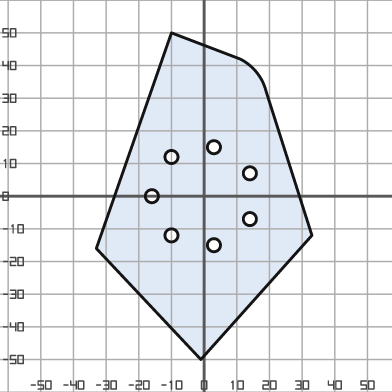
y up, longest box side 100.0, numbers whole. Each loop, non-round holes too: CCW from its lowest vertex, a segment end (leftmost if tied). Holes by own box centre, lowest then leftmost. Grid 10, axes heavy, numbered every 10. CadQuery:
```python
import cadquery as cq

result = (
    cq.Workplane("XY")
    .moveTo(-1.0, -50.0)
    .lineTo(33.0, -12.0)
    .lineTo(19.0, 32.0)
    .threePointArc((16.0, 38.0), (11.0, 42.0))
    .lineTo(-10.0, 50.0)
    .lineTo(-33.0, -16.0)
    .close()
    .moveTo(3.0, -15.0)
    .circle(2.0)
    .moveTo(-10.0, -12.0)
    .circle(2.0)
    .moveTo(14.0, -7.0)
    .circle(2.0)
    .moveTo(-16.0, 0.0)
    .circle(2.0)
    .moveTo(14.0, 7.0)
    .circle(2.0)
    .moveTo(-10.0, 12.0)
    .circle(2.0)
    .moveTo(3.0, 15.0)
    .circle(2.0)
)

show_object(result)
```